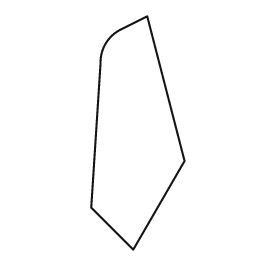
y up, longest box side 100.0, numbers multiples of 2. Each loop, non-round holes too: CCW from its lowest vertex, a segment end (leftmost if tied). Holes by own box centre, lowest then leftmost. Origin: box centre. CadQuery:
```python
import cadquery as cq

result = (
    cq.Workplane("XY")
    .moveTo(-2.0, -50.0)
    .lineTo(20.0, -12.0)
    .lineTo(4.0, 50.0)
    .lineTo(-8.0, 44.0)
    .threePointArc((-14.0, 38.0), (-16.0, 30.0))
    .lineTo(-20.0, -32.0)
    .close()
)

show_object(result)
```